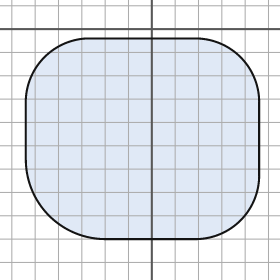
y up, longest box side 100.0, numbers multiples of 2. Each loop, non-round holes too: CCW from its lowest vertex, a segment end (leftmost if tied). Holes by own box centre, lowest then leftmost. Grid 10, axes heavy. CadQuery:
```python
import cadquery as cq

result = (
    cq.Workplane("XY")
    .moveTo(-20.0, -90.0)
    .lineTo(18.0, -90.0)
    .threePointArc((38.0, -82.0), (46.0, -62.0))
    .lineTo(46.0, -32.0)
    .threePointArc((38.0, -12.0), (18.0, -4.0))
    .lineTo(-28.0, -4.0)
    .threePointArc((-46.0, -12.0), (-54.0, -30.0))
    .lineTo(-54.0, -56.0)
    .threePointArc((-44.0, -80.0), (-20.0, -90.0))
    .close()
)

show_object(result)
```